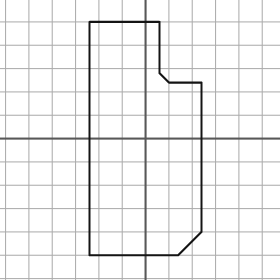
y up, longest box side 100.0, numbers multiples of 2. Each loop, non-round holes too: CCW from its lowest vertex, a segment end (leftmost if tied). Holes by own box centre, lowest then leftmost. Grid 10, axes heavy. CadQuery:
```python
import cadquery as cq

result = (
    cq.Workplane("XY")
    .moveTo(-24.0, -50.0)
    .lineTo(14.0, -50.0)
    .lineTo(24.0, -40.0)
    .lineTo(24.0, 24.0)
    .lineTo(10.0, 24.0)
    .lineTo(6.0, 28.0)
    .lineTo(6.0, 50.0)
    .lineTo(-24.0, 50.0)
    .close()
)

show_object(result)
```